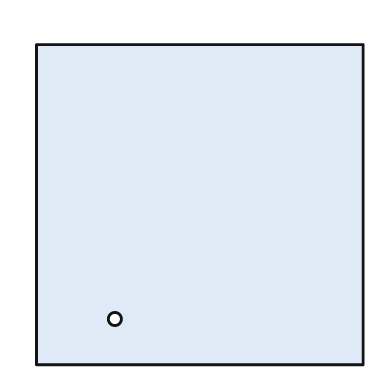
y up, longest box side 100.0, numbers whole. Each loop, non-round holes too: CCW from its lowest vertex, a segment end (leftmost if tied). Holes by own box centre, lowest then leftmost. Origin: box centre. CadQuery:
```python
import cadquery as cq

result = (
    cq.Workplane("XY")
    .moveTo(-50.0, -49.0)
    .lineTo(50.0, -49.0)
    .lineTo(50.0, 49.0)
    .lineTo(-50.0, 49.0)
    .close()
    .moveTo(-26.0, -35.0)
    .circle(2.0)
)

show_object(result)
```